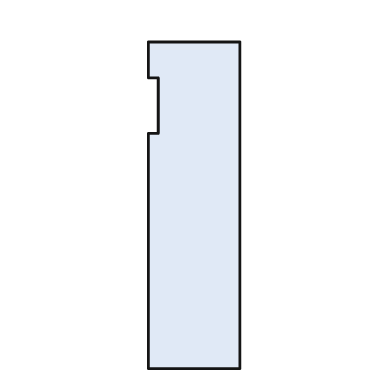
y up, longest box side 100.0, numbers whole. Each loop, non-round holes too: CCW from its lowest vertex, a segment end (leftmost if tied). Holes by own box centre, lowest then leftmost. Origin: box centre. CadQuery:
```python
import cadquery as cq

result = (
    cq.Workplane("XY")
    .moveTo(-14.0, -50.0)
    .lineTo(14.0, -50.0)
    .lineTo(14.0, 50.0)
    .lineTo(-14.0, 50.0)
    .lineTo(-14.0, 39.0)
    .lineTo(-11.0, 39.0)
    .lineTo(-11.0, 22.0)
    .lineTo(-14.0, 22.0)
    .close()
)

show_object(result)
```